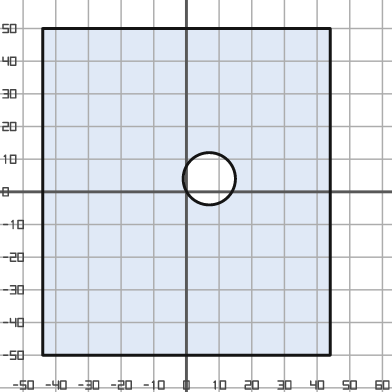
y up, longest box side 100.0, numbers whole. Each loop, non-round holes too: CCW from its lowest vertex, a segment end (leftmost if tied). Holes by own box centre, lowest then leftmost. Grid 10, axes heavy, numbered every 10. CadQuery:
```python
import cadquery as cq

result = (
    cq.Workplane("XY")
    .moveTo(-44.0, -50.0)
    .lineTo(44.0, -50.0)
    .lineTo(44.0, 50.0)
    .lineTo(-44.0, 50.0)
    .close()
    .moveTo(7.0, 4.0)
    .circle(8.0)
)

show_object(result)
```